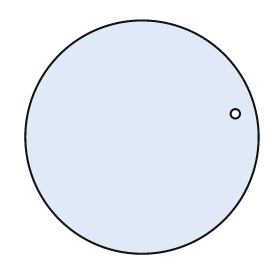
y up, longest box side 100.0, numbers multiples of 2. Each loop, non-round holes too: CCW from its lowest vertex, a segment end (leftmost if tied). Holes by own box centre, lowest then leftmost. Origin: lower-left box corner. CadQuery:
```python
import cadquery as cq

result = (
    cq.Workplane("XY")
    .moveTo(50.0, 50.0)
    .circle(50.0)
    .moveTo(90.0, 60.0)
    .circle(2.0)
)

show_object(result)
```